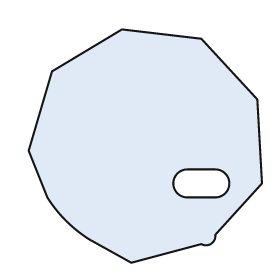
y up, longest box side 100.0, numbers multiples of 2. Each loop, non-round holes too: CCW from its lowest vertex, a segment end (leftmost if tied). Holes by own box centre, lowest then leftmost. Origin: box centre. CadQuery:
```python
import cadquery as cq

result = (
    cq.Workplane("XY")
    .moveTo(-6.0, -50.0)
    .lineTo(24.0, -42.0)
    .threePointArc((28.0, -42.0), (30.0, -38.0))
    .lineTo(50.0, -16.0)
    .lineTo(48.0, 20.0)
    .lineTo(24.0, 46.0)
    .lineTo(-10.0, 50.0)
    .lineTo(-40.0, 32.0)
    .lineTo(-50.0, -2.0)
    .lineTo(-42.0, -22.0)
    .threePointArc((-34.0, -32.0), (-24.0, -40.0))
    .close()
    .moveTo(18.0, -22.0)
    .lineTo(30.0, -22.0)
    .threePointArc((36.0, -16.0), (30.0, -10.0))
    .lineTo(18.0, -10.0)
    .threePointArc((12.0, -16.0), (18.0, -22.0))
    .close()
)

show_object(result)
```